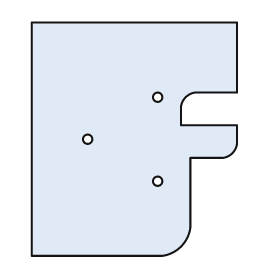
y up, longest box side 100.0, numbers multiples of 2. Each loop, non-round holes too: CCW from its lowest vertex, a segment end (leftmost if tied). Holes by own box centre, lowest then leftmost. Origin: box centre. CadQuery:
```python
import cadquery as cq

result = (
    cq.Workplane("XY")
    .moveTo(-44.0, -50.0)
    .lineTo(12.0, -50.0)
    .threePointArc((20.0, -46.0), (24.0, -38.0))
    .lineTo(24.0, -8.0)
    .lineTo(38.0, -8.0)
    .threePointArc((42.0, -6.0), (44.0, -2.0))
    .lineTo(44.0, 6.0)
    .lineTo(20.0, 6.0)
    .lineTo(20.0, 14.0)
    .threePointArc((22.0, 18.0), (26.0, 20.0))
    .lineTo(44.0, 20.0)
    .lineTo(44.0, 50.0)
    .lineTo(-44.0, 50.0)
    .close()
    .moveTo(10.0, -18.0)
    .circle(2.0)
    .moveTo(-20.0, 0.0)
    .circle(2.0)
    .moveTo(10.0, 18.0)
    .circle(2.0)
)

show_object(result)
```